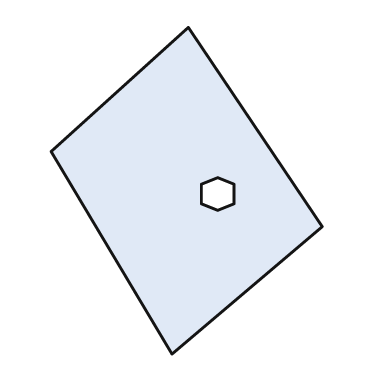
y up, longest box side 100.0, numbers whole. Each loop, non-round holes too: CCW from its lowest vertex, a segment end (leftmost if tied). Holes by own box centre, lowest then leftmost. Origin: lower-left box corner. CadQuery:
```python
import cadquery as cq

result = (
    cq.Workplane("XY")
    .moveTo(37.0, 0.0)
    .lineTo(83.0, 39.0)
    .lineTo(42.0, 100.0)
    .lineTo(0.0, 62.0)
    .close()
    .moveTo(51.0, 44.0)
    .lineTo(56.0, 46.0)
    .lineTo(56.0, 52.0)
    .lineTo(51.0, 54.0)
    .lineTo(46.0, 52.0)
    .lineTo(46.0, 46.0)
    .close()
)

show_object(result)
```